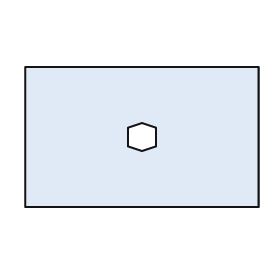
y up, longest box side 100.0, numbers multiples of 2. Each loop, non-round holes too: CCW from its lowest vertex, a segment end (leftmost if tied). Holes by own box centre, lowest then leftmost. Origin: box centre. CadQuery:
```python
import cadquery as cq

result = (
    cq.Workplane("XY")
    .moveTo(-50.0, -30.0)
    .lineTo(50.0, -30.0)
    .lineTo(50.0, 30.0)
    .lineTo(-50.0, 30.0)
    .close()
    .moveTo(0.0, -6.0)
    .lineTo(6.0, -4.0)
    .lineTo(6.0, 4.0)
    .lineTo(0.0, 6.0)
    .lineTo(-6.0, 4.0)
    .lineTo(-6.0, -4.0)
    .close()
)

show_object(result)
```